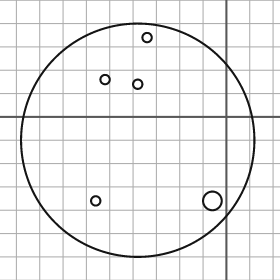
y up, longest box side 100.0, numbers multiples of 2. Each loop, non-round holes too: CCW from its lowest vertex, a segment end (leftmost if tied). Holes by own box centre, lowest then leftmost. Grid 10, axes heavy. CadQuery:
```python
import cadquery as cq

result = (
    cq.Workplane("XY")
    .moveTo(-38.0, -10.0)
    .circle(50.0)
    .moveTo(-56.0, -36.0)
    .circle(2.0)
    .moveTo(-6.0, -36.0)
    .circle(4.0)
    .moveTo(-38.0, 14.0)
    .circle(2.0)
    .moveTo(-52.0, 16.0)
    .circle(2.0)
    .moveTo(-34.0, 34.0)
    .circle(2.0)
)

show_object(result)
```